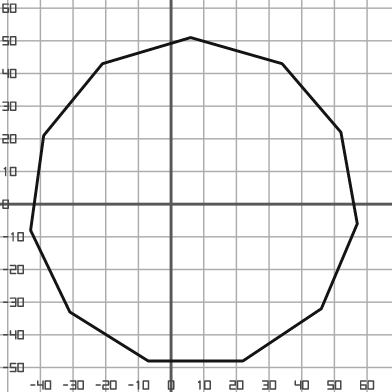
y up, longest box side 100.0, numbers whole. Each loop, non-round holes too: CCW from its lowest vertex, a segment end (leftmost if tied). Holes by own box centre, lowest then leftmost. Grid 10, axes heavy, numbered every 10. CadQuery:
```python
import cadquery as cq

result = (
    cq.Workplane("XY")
    .moveTo(-7.0, -48.0)
    .lineTo(22.0, -48.0)
    .lineTo(46.0, -32.0)
    .lineTo(57.0, -6.0)
    .lineTo(52.0, 22.0)
    .lineTo(34.0, 43.0)
    .lineTo(6.0, 51.0)
    .lineTo(-21.0, 43.0)
    .lineTo(-39.0, 21.0)
    .lineTo(-43.0, -8.0)
    .lineTo(-31.0, -33.0)
    .close()
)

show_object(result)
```